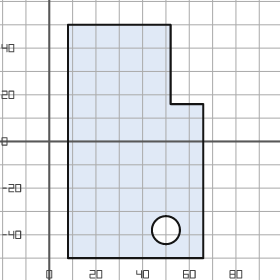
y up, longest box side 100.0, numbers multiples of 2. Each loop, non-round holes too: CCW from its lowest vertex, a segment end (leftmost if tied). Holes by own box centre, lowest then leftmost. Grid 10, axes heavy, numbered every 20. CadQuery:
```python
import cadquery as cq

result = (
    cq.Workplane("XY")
    .moveTo(8.0, -50.0)
    .lineTo(66.0, -50.0)
    .lineTo(66.0, 16.0)
    .lineTo(52.0, 16.0)
    .lineTo(52.0, 50.0)
    .lineTo(8.0, 50.0)
    .close()
    .moveTo(50.0, -38.0)
    .circle(6.0)
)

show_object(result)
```